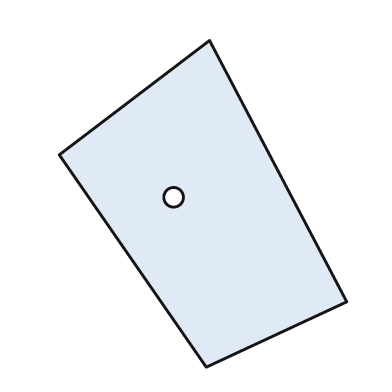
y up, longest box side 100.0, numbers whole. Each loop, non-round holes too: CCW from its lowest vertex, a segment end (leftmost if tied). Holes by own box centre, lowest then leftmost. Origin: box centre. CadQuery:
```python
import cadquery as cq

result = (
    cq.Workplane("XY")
    .moveTo(1.0, -50.0)
    .lineTo(44.0, -30.0)
    .lineTo(2.0, 50.0)
    .lineTo(-44.0, 15.0)
    .close()
    .moveTo(-9.0, 2.0)
    .circle(3.0)
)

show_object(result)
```